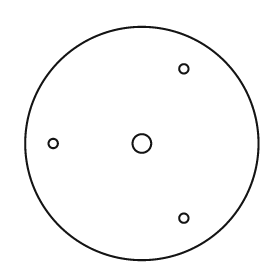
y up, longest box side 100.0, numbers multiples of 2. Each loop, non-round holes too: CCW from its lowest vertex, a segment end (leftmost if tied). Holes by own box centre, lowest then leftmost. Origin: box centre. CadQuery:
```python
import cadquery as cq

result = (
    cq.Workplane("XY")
    .moveTo(0.0, 0.0)
    .circle(50.0)
    .moveTo(18.0, -32.0)
    .circle(2.0)
    .moveTo(-38.0, 0.0)
    .circle(2.0)
    .moveTo(0.0, 0.0)
    .circle(4.0)
    .moveTo(18.0, 32.0)
    .circle(2.0)
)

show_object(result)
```